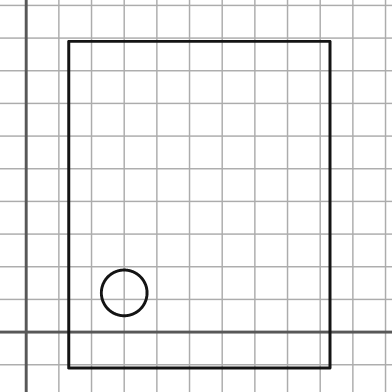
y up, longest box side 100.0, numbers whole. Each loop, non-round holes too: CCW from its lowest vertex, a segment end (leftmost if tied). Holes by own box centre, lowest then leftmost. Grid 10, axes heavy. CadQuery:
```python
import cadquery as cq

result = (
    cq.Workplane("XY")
    .moveTo(13.0, -11.0)
    .lineTo(93.0, -11.0)
    .lineTo(93.0, 89.0)
    .lineTo(13.0, 89.0)
    .close()
    .moveTo(30.0, 12.0)
    .circle(7.0)
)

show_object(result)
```